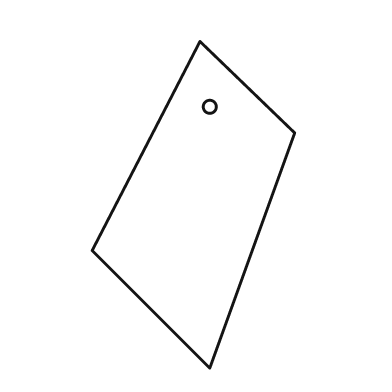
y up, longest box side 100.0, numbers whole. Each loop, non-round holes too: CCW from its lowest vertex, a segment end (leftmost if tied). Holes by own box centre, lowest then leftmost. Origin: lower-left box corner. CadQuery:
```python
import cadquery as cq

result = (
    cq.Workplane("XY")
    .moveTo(36.0, 0.0)
    .lineTo(62.0, 72.0)
    .lineTo(33.0, 100.0)
    .lineTo(0.0, 36.0)
    .close()
    .moveTo(36.0, 80.0)
    .circle(2.0)
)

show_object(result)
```